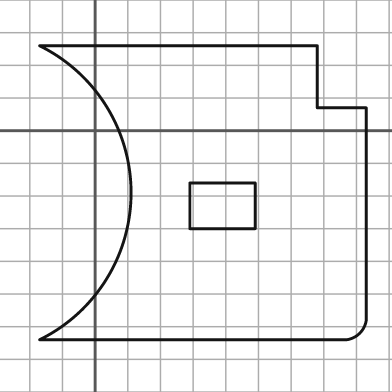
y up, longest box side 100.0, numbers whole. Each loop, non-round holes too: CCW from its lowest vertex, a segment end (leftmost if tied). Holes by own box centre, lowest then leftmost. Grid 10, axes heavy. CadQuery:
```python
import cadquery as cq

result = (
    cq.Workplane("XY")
    .moveTo(-17.0, -64.0)
    .lineTo(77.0, -64.0)
    .threePointArc((81.0, -62.0), (83.0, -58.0))
    .lineTo(83.0, 7.0)
    .lineTo(68.0, 7.0)
    .lineTo(68.0, 26.0)
    .lineTo(-17.0, 26.0)
    .threePointArc((11.0, -19.0), (-17.0, -64.0))
    .close()
    .moveTo(29.0, -30.0)
    .lineTo(49.0, -30.0)
    .lineTo(49.0, -16.0)
    .lineTo(29.0, -16.0)
    .close()
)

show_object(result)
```